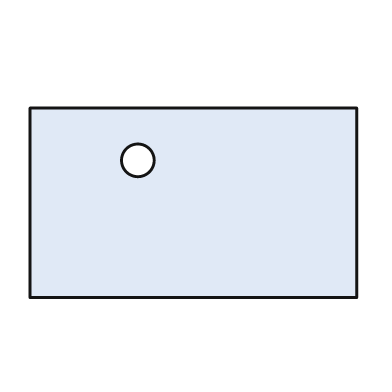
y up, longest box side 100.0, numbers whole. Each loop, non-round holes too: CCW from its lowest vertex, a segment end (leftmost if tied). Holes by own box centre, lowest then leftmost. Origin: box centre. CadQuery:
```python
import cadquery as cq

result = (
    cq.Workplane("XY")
    .moveTo(-50.0, -29.0)
    .lineTo(50.0, -29.0)
    .lineTo(50.0, 29.0)
    .lineTo(-50.0, 29.0)
    .close()
    .moveTo(-17.0, 13.0)
    .circle(5.0)
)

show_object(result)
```